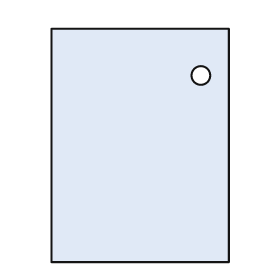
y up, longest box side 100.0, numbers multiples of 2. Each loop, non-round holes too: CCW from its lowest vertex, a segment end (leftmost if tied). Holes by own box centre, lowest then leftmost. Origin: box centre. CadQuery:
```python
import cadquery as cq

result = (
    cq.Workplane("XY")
    .moveTo(-38.0, -50.0)
    .lineTo(38.0, -50.0)
    .lineTo(38.0, 50.0)
    .lineTo(-38.0, 50.0)
    .close()
    .moveTo(26.0, 30.0)
    .circle(4.0)
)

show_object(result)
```